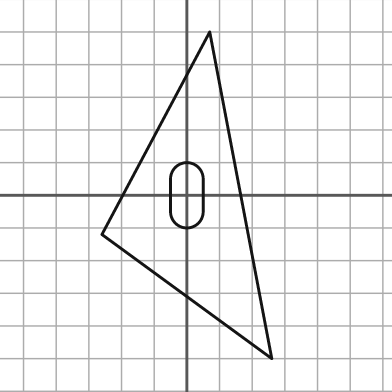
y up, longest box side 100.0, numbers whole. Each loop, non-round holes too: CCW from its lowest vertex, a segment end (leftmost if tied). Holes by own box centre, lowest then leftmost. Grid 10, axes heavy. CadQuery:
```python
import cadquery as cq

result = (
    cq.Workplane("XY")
    .moveTo(26.0, -50.0)
    .lineTo(7.0, 50.0)
    .lineTo(-26.0, -12.0)
    .close()
    .moveTo(-5.0, -5.0)
    .threePointArc((0.0, -10.0), (5.0, -5.0))
    .lineTo(5.0, 5.0)
    .threePointArc((0.0, 10.0), (-5.0, 5.0))
    .close()
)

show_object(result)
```